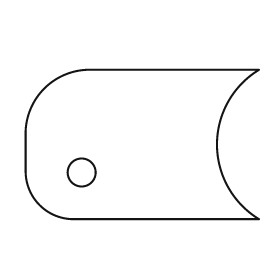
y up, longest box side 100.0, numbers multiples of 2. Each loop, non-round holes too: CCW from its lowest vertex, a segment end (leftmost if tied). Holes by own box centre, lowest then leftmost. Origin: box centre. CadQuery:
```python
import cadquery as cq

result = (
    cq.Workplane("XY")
    .moveTo(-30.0, -32.0)
    .lineTo(50.0, -32.0)
    .threePointArc((32.0, 0.0), (50.0, 32.0))
    .lineTo(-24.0, 32.0)
    .threePointArc((-42.0, 24.0), (-50.0, 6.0))
    .lineTo(-50.0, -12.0)
    .threePointArc((-44.0, -26.0), (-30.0, -32.0))
    .close()
    .moveTo(-26.0, -12.0)
    .circle(6.0)
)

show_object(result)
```